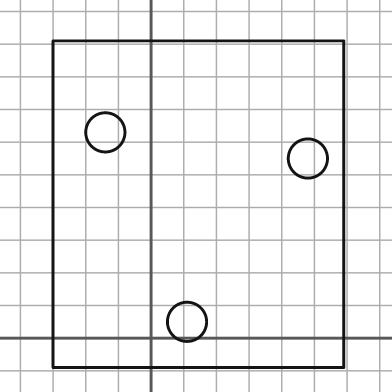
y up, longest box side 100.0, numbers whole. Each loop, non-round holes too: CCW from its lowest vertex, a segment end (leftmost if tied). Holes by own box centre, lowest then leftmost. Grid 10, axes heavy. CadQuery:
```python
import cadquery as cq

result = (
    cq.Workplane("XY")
    .moveTo(-30.0, -9.0)
    .lineTo(59.0, -9.0)
    .lineTo(59.0, 91.0)
    .lineTo(-30.0, 91.0)
    .close()
    .moveTo(11.0, 5.0)
    .circle(6.0)
    .moveTo(48.0, 55.0)
    .circle(6.0)
    .moveTo(-14.0, 63.0)
    .circle(6.0)
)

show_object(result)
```